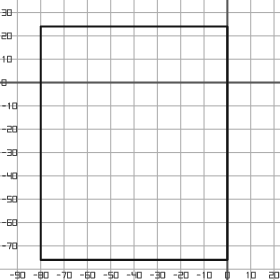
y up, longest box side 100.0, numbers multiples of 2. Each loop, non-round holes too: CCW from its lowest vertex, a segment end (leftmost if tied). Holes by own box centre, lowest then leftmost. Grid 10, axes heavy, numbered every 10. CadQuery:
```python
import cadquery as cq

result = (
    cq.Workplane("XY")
    .moveTo(-80.0, -76.0)
    .lineTo(0.0, -76.0)
    .lineTo(0.0, 24.0)
    .lineTo(-80.0, 24.0)
    .close()
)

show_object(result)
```